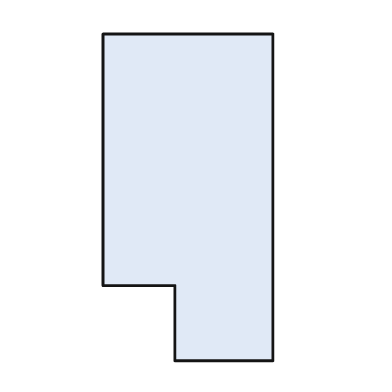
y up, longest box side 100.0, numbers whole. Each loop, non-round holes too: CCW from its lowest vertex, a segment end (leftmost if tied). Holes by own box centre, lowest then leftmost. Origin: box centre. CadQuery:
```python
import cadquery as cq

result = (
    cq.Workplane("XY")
    .moveTo(-4.0, -50.0)
    .lineTo(26.0, -50.0)
    .lineTo(26.0, 50.0)
    .lineTo(-26.0, 50.0)
    .lineTo(-26.0, -27.0)
    .lineTo(-4.0, -27.0)
    .close()
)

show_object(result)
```